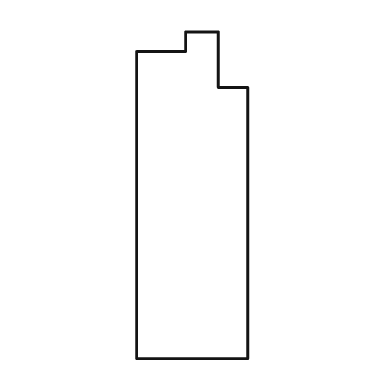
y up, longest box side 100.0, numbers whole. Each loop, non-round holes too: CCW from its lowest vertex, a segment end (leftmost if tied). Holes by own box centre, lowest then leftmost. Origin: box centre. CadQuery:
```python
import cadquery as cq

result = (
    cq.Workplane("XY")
    .moveTo(-17.0, -50.0)
    .lineTo(17.0, -50.0)
    .lineTo(17.0, 33.0)
    .lineTo(8.0, 33.0)
    .lineTo(8.0, 50.0)
    .lineTo(-2.0, 50.0)
    .lineTo(-2.0, 44.0)
    .lineTo(-17.0, 44.0)
    .close()
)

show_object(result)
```